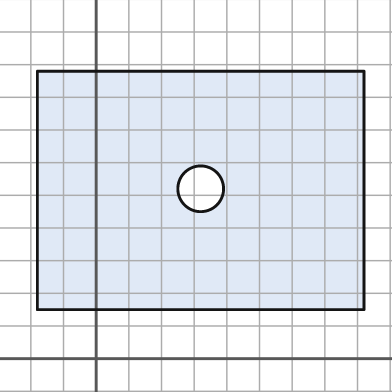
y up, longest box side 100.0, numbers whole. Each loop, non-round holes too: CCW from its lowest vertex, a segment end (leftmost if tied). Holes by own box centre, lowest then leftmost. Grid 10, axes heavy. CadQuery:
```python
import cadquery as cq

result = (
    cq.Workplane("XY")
    .moveTo(-18.0, 15.0)
    .lineTo(82.0, 15.0)
    .lineTo(82.0, 88.0)
    .lineTo(-18.0, 88.0)
    .close()
    .moveTo(32.0, 52.0)
    .circle(7.0)
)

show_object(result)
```